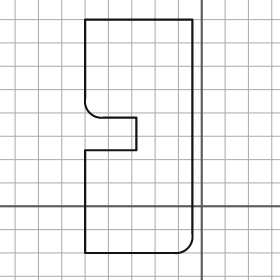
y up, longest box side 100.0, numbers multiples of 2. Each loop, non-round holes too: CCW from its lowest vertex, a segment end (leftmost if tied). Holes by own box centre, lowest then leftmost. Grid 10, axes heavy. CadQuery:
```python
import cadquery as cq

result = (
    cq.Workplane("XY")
    .moveTo(-50.0, -20.0)
    .lineTo(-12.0, -20.0)
    .threePointArc((-6.0, -18.0), (-4.0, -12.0))
    .lineTo(-4.0, 80.0)
    .lineTo(-50.0, 80.0)
    .lineTo(-50.0, 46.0)
    .threePointArc((-48.0, 40.0), (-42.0, 38.0))
    .lineTo(-28.0, 38.0)
    .lineTo(-28.0, 24.0)
    .lineTo(-50.0, 24.0)
    .close()
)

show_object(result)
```